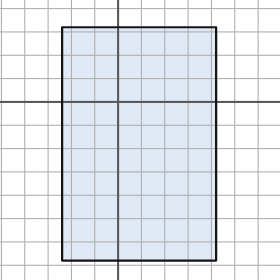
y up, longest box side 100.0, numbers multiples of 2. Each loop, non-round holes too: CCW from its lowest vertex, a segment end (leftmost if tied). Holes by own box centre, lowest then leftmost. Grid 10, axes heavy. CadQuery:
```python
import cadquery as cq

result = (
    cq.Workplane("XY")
    .moveTo(-24.0, -68.0)
    .lineTo(42.0, -68.0)
    .lineTo(42.0, 32.0)
    .lineTo(-24.0, 32.0)
    .close()
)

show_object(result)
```